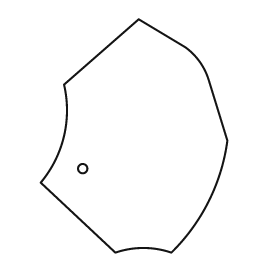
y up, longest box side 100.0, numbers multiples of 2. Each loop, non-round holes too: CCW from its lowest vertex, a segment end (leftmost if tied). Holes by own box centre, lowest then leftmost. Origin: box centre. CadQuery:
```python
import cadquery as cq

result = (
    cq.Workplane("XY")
    .moveTo(-8.0, -50.0)
    .threePointArc((4.0, -48.0), (16.0, -50.0))
    .threePointArc((32.0, -28.0), (40.0, -2.0))
    .lineTo(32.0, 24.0)
    .threePointArc((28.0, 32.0), (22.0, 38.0))
    .lineTo(2.0, 50.0)
    .lineTo(-30.0, 22.0)
    .threePointArc((-30.0, 0.0), (-40.0, -20.0))
    .close()
    .moveTo(-22.0, -14.0)
    .circle(2.0)
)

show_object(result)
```